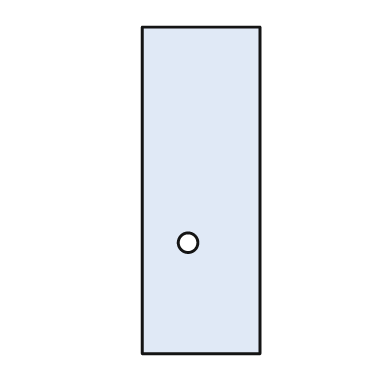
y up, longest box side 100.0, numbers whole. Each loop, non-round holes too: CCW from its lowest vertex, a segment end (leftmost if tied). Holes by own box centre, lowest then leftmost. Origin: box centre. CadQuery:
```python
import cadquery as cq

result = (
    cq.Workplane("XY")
    .moveTo(-18.0, -50.0)
    .lineTo(18.0, -50.0)
    .lineTo(18.0, 50.0)
    .lineTo(-18.0, 50.0)
    .close()
    .moveTo(-4.0, -16.0)
    .circle(3.0)
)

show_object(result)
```